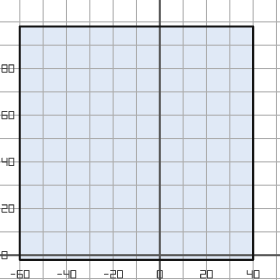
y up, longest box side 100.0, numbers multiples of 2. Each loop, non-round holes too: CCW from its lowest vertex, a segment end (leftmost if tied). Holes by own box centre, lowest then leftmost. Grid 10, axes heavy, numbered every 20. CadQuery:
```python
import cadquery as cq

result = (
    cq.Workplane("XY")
    .moveTo(-60.0, -2.0)
    .lineTo(40.0, -2.0)
    .lineTo(40.0, 98.0)
    .lineTo(-60.0, 98.0)
    .close()
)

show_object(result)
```